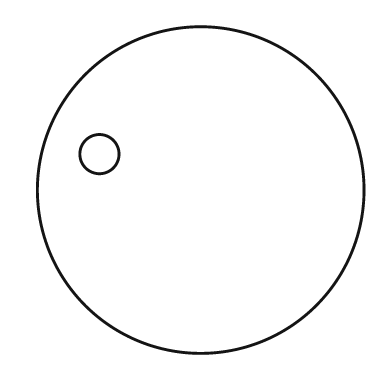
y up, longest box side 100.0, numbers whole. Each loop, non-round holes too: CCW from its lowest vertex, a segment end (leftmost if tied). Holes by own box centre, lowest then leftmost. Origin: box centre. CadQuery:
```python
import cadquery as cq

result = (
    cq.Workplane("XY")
    .moveTo(0.0, 0.0)
    .circle(50.0)
    .moveTo(-31.0, 11.0)
    .circle(6.0)
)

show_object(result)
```